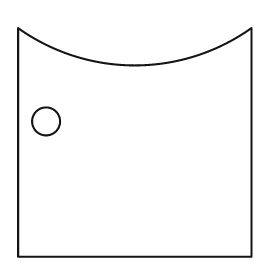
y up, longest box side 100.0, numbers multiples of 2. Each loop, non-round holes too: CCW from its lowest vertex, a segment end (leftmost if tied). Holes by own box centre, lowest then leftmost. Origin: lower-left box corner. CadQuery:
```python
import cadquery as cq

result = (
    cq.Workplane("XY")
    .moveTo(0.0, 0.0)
    .lineTo(100.0, 0.0)
    .lineTo(100.0, 98.0)
    .threePointArc((50.0, 82.0), (0.0, 98.0))
    .close()
    .moveTo(12.0, 58.0)
    .circle(6.0)
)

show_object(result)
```